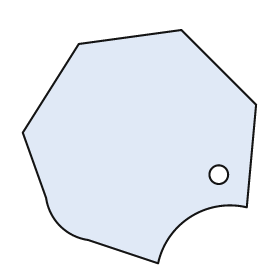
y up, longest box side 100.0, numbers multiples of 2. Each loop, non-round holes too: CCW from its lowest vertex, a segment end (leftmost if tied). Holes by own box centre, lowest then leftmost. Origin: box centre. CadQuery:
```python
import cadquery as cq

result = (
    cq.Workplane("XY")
    .moveTo(8.0, -50.0)
    .threePointArc((22.0, -30.0), (46.0, -26.0))
    .lineTo(50.0, 18.0)
    .lineTo(18.0, 50.0)
    .lineTo(-26.0, 44.0)
    .lineTo(-50.0, 6.0)
    .lineTo(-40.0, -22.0)
    .threePointArc((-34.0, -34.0), (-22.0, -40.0))
    .close()
    .moveTo(34.0, -12.0)
    .circle(4.0)
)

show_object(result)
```